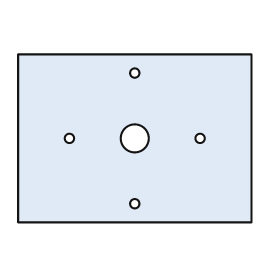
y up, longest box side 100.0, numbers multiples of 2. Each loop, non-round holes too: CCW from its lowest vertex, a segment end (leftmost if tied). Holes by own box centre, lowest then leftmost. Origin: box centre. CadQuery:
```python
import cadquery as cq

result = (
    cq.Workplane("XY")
    .moveTo(-50.0, -36.0)
    .lineTo(50.0, -36.0)
    .lineTo(50.0, 36.0)
    .lineTo(-50.0, 36.0)
    .close()
    .moveTo(0.0, -28.0)
    .circle(2.0)
    .moveTo(-28.0, 0.0)
    .circle(2.0)
    .moveTo(0.0, 0.0)
    .circle(6.0)
    .moveTo(28.0, 0.0)
    .circle(2.0)
    .moveTo(0.0, 28.0)
    .circle(2.0)
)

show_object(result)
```